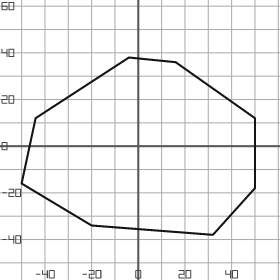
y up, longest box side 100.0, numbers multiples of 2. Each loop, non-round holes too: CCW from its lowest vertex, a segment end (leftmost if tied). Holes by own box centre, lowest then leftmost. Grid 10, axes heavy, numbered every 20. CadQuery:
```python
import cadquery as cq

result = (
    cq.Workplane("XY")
    .moveTo(32.0, -38.0)
    .lineTo(50.0, -18.0)
    .lineTo(50.0, 12.0)
    .lineTo(16.0, 36.0)
    .lineTo(-4.0, 38.0)
    .lineTo(-44.0, 12.0)
    .lineTo(-50.0, -16.0)
    .lineTo(-20.0, -34.0)
    .close()
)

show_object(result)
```